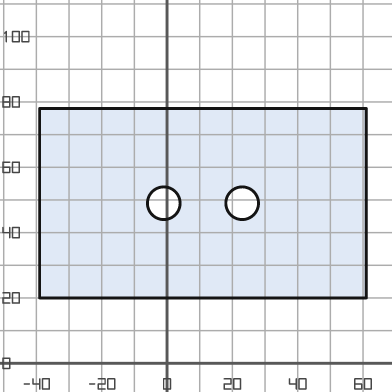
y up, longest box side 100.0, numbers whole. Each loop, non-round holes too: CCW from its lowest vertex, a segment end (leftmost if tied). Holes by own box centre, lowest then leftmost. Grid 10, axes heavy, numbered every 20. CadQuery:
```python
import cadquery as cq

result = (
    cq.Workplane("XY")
    .moveTo(-39.0, 20.0)
    .lineTo(61.0, 20.0)
    .lineTo(61.0, 78.0)
    .lineTo(-39.0, 78.0)
    .close()
    .moveTo(-1.0, 49.0)
    .circle(5.0)
    .moveTo(23.0, 49.0)
    .circle(5.0)
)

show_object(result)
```